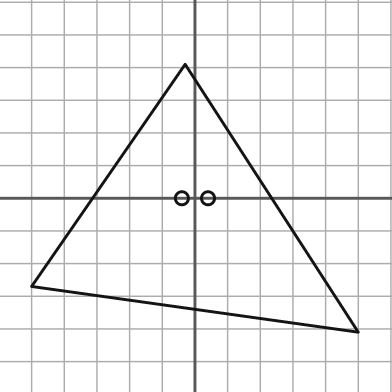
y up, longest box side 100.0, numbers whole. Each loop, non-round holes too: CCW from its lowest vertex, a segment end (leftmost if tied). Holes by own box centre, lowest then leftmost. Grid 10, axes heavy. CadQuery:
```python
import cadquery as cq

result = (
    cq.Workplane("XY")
    .moveTo(50.0, -41.0)
    .lineTo(-3.0, 41.0)
    .lineTo(-50.0, -27.0)
    .close()
    .moveTo(-4.0, 0.0)
    .circle(2.0)
    .moveTo(4.0, 0.0)
    .circle(2.0)
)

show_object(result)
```